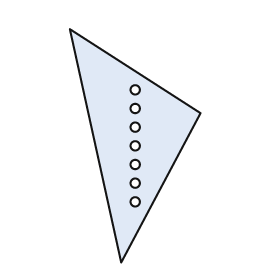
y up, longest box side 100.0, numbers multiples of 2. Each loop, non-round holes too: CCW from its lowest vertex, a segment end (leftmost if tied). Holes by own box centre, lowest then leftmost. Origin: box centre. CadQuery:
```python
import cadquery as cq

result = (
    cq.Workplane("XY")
    .moveTo(-6.0, -50.0)
    .lineTo(28.0, 14.0)
    .lineTo(-28.0, 50.0)
    .close()
    .moveTo(0.0, -24.0)
    .circle(2.0)
    .moveTo(0.0, -16.0)
    .circle(2.0)
    .moveTo(0.0, -8.0)
    .circle(2.0)
    .moveTo(0.0, 0.0)
    .circle(2.0)
    .moveTo(0.0, 8.0)
    .circle(2.0)
    .moveTo(0.0, 16.0)
    .circle(2.0)
    .moveTo(0.0, 24.0)
    .circle(2.0)
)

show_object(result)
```